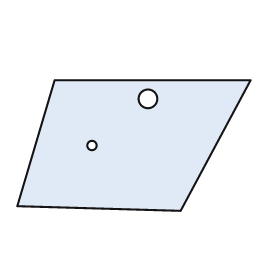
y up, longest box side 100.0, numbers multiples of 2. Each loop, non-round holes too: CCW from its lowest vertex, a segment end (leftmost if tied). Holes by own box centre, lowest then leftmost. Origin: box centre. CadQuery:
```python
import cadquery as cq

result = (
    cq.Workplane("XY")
    .moveTo(20.0, -28.0)
    .lineTo(50.0, 28.0)
    .lineTo(-34.0, 28.0)
    .lineTo(-50.0, -26.0)
    .close()
    .moveTo(-18.0, 0.0)
    .circle(2.0)
    .moveTo(6.0, 20.0)
    .circle(4.0)
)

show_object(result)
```